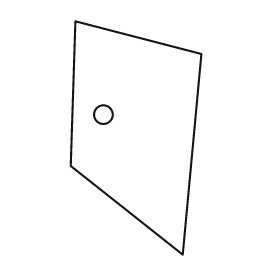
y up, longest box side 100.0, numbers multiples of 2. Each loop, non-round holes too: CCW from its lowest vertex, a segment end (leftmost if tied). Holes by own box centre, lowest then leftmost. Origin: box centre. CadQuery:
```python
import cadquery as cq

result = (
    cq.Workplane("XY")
    .moveTo(20.0, -50.0)
    .lineTo(28.0, 36.0)
    .lineTo(-26.0, 50.0)
    .lineTo(-28.0, -12.0)
    .close()
    .moveTo(-14.0, 10.0)
    .circle(4.0)
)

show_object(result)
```